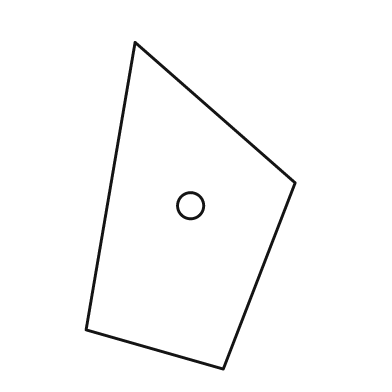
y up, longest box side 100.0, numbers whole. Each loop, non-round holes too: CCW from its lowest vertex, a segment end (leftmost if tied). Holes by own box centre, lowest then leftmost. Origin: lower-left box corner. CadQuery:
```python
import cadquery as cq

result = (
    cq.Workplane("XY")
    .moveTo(42.0, 0.0)
    .lineTo(64.0, 57.0)
    .lineTo(15.0, 100.0)
    .lineTo(0.0, 12.0)
    .close()
    .moveTo(32.0, 50.0)
    .circle(4.0)
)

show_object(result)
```